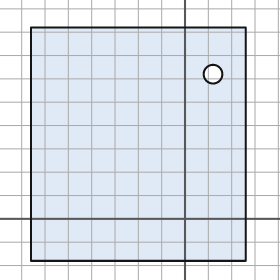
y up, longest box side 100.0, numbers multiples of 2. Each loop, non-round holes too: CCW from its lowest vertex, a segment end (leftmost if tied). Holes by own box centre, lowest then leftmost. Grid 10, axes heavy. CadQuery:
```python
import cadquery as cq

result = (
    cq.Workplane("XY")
    .moveTo(-66.0, -18.0)
    .lineTo(26.0, -18.0)
    .lineTo(26.0, 82.0)
    .lineTo(-66.0, 82.0)
    .close()
    .moveTo(12.0, 62.0)
    .circle(4.0)
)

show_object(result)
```